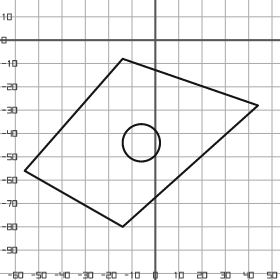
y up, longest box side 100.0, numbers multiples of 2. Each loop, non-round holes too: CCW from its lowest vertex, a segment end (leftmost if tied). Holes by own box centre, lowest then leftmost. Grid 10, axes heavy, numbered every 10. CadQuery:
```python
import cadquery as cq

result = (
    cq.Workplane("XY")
    .moveTo(-14.0, -80.0)
    .lineTo(44.0, -28.0)
    .lineTo(-14.0, -8.0)
    .lineTo(-56.0, -56.0)
    .close()
    .moveTo(-6.0, -44.0)
    .circle(8.0)
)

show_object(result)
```